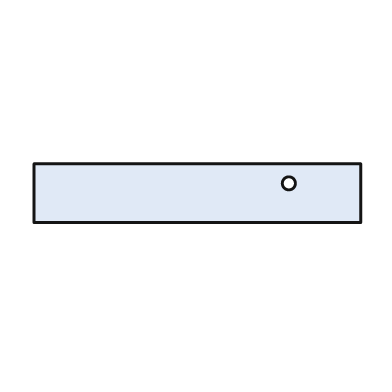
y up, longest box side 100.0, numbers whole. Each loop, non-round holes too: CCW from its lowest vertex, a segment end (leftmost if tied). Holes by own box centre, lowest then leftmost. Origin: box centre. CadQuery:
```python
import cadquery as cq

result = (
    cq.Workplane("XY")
    .moveTo(-50.0, -9.0)
    .lineTo(50.0, -9.0)
    .lineTo(50.0, 9.0)
    .lineTo(-50.0, 9.0)
    .close()
    .moveTo(28.0, 3.0)
    .circle(2.0)
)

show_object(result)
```